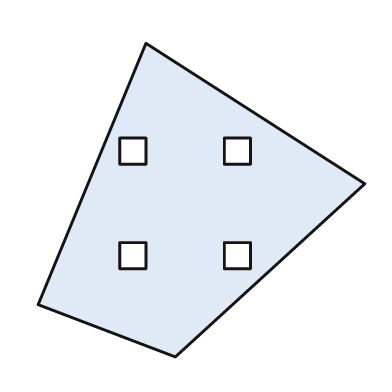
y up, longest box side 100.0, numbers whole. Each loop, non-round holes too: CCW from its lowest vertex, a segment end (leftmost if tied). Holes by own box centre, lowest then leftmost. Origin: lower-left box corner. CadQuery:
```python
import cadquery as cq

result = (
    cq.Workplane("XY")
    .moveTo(42.0, 0.0)
    .lineTo(100.0, 53.0)
    .lineTo(33.0, 96.0)
    .lineTo(0.0, 16.0)
    .close()
    .moveTo(25.0, 27.0)
    .lineTo(33.0, 27.0)
    .lineTo(33.0, 35.0)
    .lineTo(25.0, 35.0)
    .close()
    .moveTo(57.0, 27.0)
    .lineTo(65.0, 27.0)
    .lineTo(65.0, 35.0)
    .lineTo(57.0, 35.0)
    .close()
    .moveTo(25.0, 59.0)
    .lineTo(33.0, 59.0)
    .lineTo(33.0, 67.0)
    .lineTo(25.0, 67.0)
    .close()
    .moveTo(57.0, 59.0)
    .lineTo(65.0, 59.0)
    .lineTo(65.0, 67.0)
    .lineTo(57.0, 67.0)
    .close()
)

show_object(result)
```